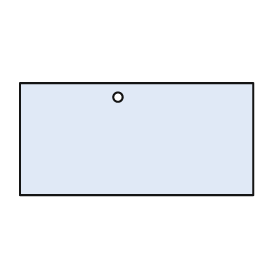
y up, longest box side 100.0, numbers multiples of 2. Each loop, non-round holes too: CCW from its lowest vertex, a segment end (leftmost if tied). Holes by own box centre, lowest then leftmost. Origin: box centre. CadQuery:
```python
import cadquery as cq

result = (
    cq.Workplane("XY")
    .moveTo(-50.0, -24.0)
    .lineTo(50.0, -24.0)
    .lineTo(50.0, 24.0)
    .lineTo(-50.0, 24.0)
    .close()
    .moveTo(-8.0, 18.0)
    .circle(2.0)
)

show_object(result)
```